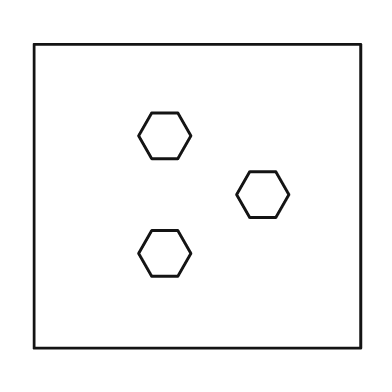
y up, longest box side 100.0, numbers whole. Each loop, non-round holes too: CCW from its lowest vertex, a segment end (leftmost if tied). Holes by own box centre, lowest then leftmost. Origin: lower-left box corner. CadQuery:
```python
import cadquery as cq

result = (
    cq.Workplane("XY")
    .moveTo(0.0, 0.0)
    .lineTo(100.0, 0.0)
    .lineTo(100.0, 93.0)
    .lineTo(0.0, 93.0)
    .close()
    .moveTo(36.0, 22.0)
    .lineTo(44.0, 22.0)
    .lineTo(48.0, 29.0)
    .lineTo(44.0, 36.0)
    .lineTo(36.0, 36.0)
    .lineTo(32.0, 29.0)
    .close()
    .moveTo(66.0, 40.0)
    .lineTo(74.0, 40.0)
    .lineTo(78.0, 47.0)
    .lineTo(74.0, 54.0)
    .lineTo(66.0, 54.0)
    .lineTo(62.0, 47.0)
    .close()
    .moveTo(36.0, 58.0)
    .lineTo(44.0, 58.0)
    .lineTo(48.0, 65.0)
    .lineTo(44.0, 72.0)
    .lineTo(36.0, 72.0)
    .lineTo(32.0, 65.0)
    .close()
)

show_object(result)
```